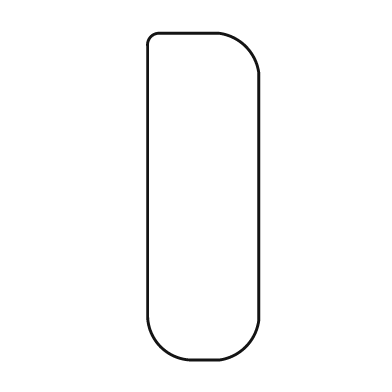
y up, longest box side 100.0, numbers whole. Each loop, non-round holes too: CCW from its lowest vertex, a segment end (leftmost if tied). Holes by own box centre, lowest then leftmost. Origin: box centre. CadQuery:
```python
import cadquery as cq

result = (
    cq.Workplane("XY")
    .moveTo(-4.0, -50.0)
    .lineTo(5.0, -50.0)
    .threePointArc((13.0, -46.0), (17.0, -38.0))
    .lineTo(17.0, 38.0)
    .threePointArc((13.0, 46.0), (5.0, 50.0))
    .lineTo(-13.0, 50.0)
    .threePointArc((-16.0, 49.0), (-17.0, 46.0))
    .lineTo(-17.0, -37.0)
    .threePointArc((-13.0, -46.0), (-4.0, -50.0))
    .close()
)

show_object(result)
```